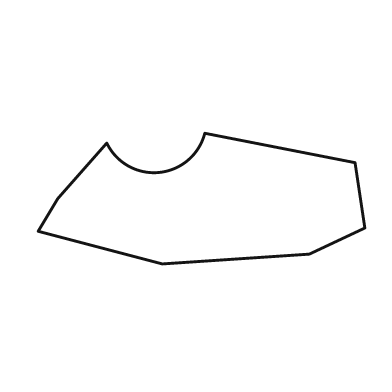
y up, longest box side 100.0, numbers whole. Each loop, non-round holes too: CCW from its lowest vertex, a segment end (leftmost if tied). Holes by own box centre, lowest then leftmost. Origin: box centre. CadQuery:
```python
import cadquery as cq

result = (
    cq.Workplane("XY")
    .moveTo(-12.0, -20.0)
    .lineTo(33.0, -17.0)
    .lineTo(50.0, -9.0)
    .lineTo(47.0, 11.0)
    .lineTo(1.0, 20.0)
    .threePointArc((-13.0, 8.0), (-29.0, 17.0))
    .lineTo(-44.0, 0.0)
    .lineTo(-50.0, -10.0)
    .close()
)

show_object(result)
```